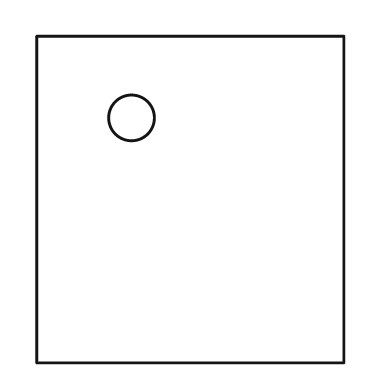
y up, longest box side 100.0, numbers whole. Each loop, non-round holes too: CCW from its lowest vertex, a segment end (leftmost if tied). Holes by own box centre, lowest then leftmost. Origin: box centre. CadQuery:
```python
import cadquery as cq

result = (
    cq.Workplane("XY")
    .moveTo(-47.0, -50.0)
    .lineTo(47.0, -50.0)
    .lineTo(47.0, 50.0)
    .lineTo(-47.0, 50.0)
    .close()
    .moveTo(-18.0, 25.0)
    .circle(7.0)
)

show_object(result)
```